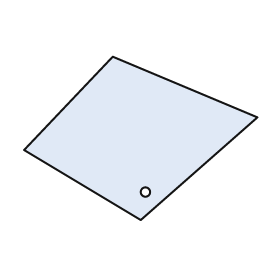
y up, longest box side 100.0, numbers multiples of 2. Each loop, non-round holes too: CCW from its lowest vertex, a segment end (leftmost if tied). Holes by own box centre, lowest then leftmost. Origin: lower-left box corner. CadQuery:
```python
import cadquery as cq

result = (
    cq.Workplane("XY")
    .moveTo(50.0, 0.0)
    .lineTo(100.0, 44.0)
    .lineTo(38.0, 70.0)
    .lineTo(0.0, 30.0)
    .close()
    .moveTo(52.0, 12.0)
    .circle(2.0)
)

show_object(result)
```